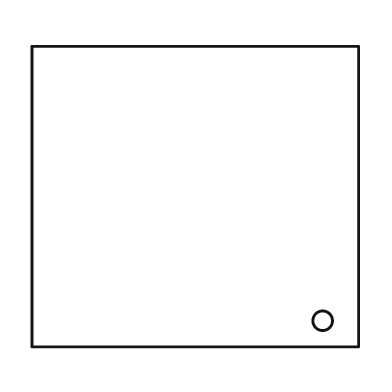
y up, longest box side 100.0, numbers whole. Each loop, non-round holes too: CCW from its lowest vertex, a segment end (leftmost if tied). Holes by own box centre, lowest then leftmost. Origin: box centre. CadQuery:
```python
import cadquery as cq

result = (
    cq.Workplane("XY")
    .moveTo(-50.0, -46.0)
    .lineTo(50.0, -46.0)
    .lineTo(50.0, 46.0)
    .lineTo(-50.0, 46.0)
    .close()
    .moveTo(39.0, -38.0)
    .circle(3.0)
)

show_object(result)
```